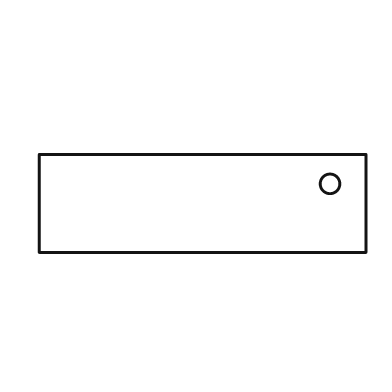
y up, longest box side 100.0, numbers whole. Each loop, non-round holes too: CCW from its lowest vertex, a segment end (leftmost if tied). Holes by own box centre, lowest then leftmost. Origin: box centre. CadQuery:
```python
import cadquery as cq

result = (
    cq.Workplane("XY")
    .moveTo(-50.0, -15.0)
    .lineTo(50.0, -15.0)
    .lineTo(50.0, 15.0)
    .lineTo(-50.0, 15.0)
    .close()
    .moveTo(39.0, 6.0)
    .circle(3.0)
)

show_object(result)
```